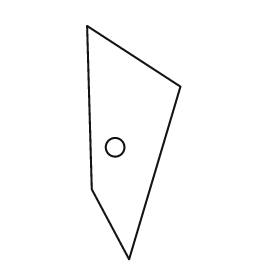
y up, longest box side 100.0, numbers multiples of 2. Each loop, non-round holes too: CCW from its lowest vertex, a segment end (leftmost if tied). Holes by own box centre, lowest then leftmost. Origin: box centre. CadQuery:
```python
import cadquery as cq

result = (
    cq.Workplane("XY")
    .moveTo(-2.0, -50.0)
    .lineTo(20.0, 24.0)
    .lineTo(-20.0, 50.0)
    .lineTo(-18.0, -20.0)
    .close()
    .moveTo(-8.0, -2.0)
    .circle(4.0)
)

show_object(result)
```